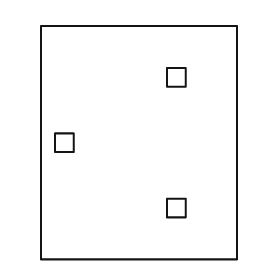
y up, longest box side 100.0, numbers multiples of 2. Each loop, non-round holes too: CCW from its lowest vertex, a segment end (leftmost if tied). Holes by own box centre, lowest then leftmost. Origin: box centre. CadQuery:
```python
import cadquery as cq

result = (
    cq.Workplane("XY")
    .moveTo(-42.0, -50.0)
    .lineTo(42.0, -50.0)
    .lineTo(42.0, 50.0)
    .lineTo(-42.0, 50.0)
    .close()
    .moveTo(12.0, -32.0)
    .lineTo(20.0, -32.0)
    .lineTo(20.0, -24.0)
    .lineTo(12.0, -24.0)
    .close()
    .moveTo(-36.0, -4.0)
    .lineTo(-28.0, -4.0)
    .lineTo(-28.0, 4.0)
    .lineTo(-36.0, 4.0)
    .close()
    .moveTo(12.0, 24.0)
    .lineTo(20.0, 24.0)
    .lineTo(20.0, 32.0)
    .lineTo(12.0, 32.0)
    .close()
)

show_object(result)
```